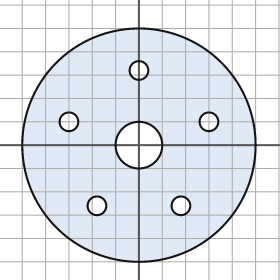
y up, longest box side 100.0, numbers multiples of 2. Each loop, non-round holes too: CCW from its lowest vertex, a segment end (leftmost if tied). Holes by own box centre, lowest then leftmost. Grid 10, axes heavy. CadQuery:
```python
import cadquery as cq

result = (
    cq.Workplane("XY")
    .moveTo(0.0, 0.0)
    .circle(50.0)
    .moveTo(-18.0, -26.0)
    .circle(4.0)
    .moveTo(18.0, -26.0)
    .circle(4.0)
    .moveTo(0.0, 0.0)
    .circle(10.0)
    .moveTo(-30.0, 10.0)
    .circle(4.0)
    .moveTo(30.0, 10.0)
    .circle(4.0)
    .moveTo(0.0, 32.0)
    .circle(4.0)
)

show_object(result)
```